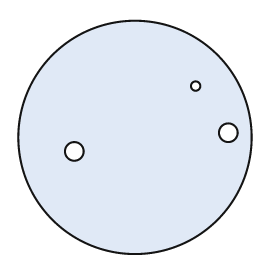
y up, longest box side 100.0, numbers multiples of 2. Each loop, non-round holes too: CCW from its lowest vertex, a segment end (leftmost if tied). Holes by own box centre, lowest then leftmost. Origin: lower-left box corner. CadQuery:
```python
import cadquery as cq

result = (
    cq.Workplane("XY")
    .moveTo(50.0, 50.0)
    .circle(50.0)
    .moveTo(24.0, 44.0)
    .circle(4.0)
    .moveTo(90.0, 52.0)
    .circle(4.0)
    .moveTo(76.0, 72.0)
    .circle(2.0)
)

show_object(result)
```